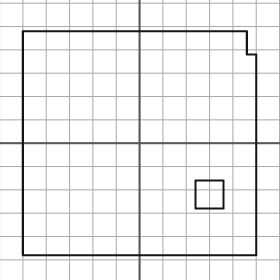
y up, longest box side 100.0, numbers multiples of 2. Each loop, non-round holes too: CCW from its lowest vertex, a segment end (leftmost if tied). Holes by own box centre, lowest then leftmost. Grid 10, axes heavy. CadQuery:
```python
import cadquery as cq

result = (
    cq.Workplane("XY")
    .moveTo(-50.0, -48.0)
    .lineTo(50.0, -48.0)
    .lineTo(50.0, 38.0)
    .lineTo(46.0, 38.0)
    .lineTo(46.0, 48.0)
    .lineTo(-50.0, 48.0)
    .close()
    .moveTo(24.0, -28.0)
    .lineTo(36.0, -28.0)
    .lineTo(36.0, -16.0)
    .lineTo(24.0, -16.0)
    .close()
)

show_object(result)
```